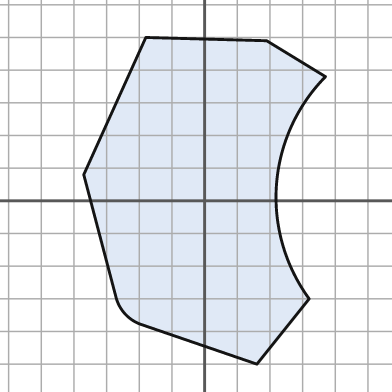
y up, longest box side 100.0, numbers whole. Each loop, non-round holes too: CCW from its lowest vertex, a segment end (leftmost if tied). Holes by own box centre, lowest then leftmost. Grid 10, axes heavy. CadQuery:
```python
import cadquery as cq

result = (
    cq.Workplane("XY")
    .moveTo(16.0, -50.0)
    .lineTo(32.0, -30.0)
    .threePointArc((22.0, 5.0), (37.0, 38.0))
    .lineTo(19.0, 49.0)
    .lineTo(-18.0, 50.0)
    .lineTo(-37.0, 8.0)
    .lineTo(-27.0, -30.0)
    .threePointArc((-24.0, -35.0), (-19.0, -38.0))
    .close()
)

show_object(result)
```